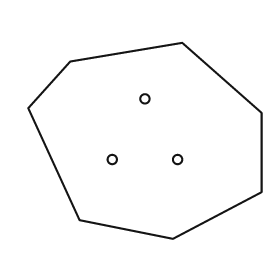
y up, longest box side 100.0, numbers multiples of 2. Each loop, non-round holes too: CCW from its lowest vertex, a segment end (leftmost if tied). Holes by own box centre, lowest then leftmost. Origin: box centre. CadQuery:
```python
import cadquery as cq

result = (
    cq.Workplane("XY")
    .moveTo(12.0, -42.0)
    .lineTo(50.0, -22.0)
    .lineTo(50.0, 12.0)
    .lineTo(16.0, 42.0)
    .lineTo(-32.0, 34.0)
    .lineTo(-50.0, 14.0)
    .lineTo(-28.0, -34.0)
    .close()
    .moveTo(-14.0, -8.0)
    .circle(2.0)
    .moveTo(14.0, -8.0)
    .circle(2.0)
    .moveTo(0.0, 18.0)
    .circle(2.0)
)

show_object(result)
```